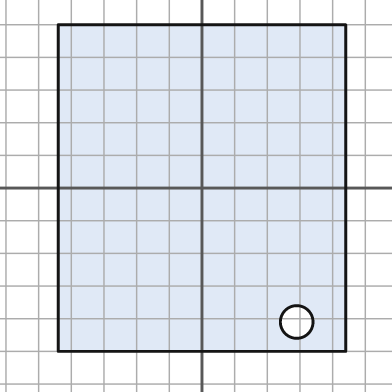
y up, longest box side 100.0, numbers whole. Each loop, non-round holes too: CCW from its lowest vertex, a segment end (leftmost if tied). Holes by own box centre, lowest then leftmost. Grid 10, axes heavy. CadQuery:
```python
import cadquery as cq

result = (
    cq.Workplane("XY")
    .moveTo(-44.0, -50.0)
    .lineTo(44.0, -50.0)
    .lineTo(44.0, 50.0)
    .lineTo(-44.0, 50.0)
    .close()
    .moveTo(29.0, -41.0)
    .circle(5.0)
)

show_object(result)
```